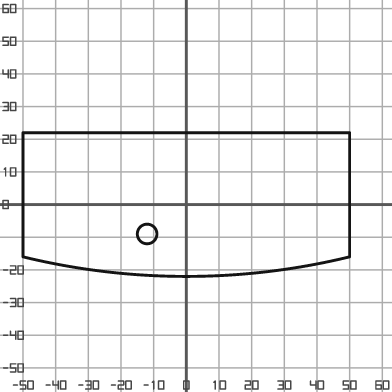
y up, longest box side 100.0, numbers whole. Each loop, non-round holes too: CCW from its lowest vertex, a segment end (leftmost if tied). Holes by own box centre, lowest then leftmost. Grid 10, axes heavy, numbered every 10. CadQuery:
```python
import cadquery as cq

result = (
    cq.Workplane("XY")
    .moveTo(-50.0, -16.0)
    .threePointArc((0.0, -22.0), (50.0, -16.0))
    .lineTo(50.0, 22.0)
    .lineTo(-50.0, 22.0)
    .close()
    .moveTo(-12.0, -9.0)
    .circle(3.0)
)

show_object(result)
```